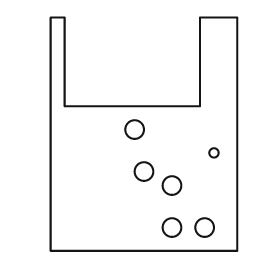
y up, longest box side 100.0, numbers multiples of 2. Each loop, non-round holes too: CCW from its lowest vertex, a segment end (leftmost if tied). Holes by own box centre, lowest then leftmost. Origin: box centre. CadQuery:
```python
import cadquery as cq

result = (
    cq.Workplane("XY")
    .moveTo(-40.0, -50.0)
    .lineTo(40.0, -50.0)
    .lineTo(40.0, 50.0)
    .lineTo(24.0, 50.0)
    .lineTo(24.0, 12.0)
    .lineTo(-34.0, 12.0)
    .lineTo(-34.0, 50.0)
    .lineTo(-40.0, 50.0)
    .close()
    .moveTo(12.0, -40.0)
    .circle(4.0)
    .moveTo(26.0, -40.0)
    .circle(4.0)
    .moveTo(12.0, -22.0)
    .circle(4.0)
    .moveTo(0.0, -16.0)
    .circle(4.0)
    .moveTo(30.0, -8.0)
    .circle(2.0)
    .moveTo(-4.0, 2.0)
    .circle(4.0)
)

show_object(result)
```